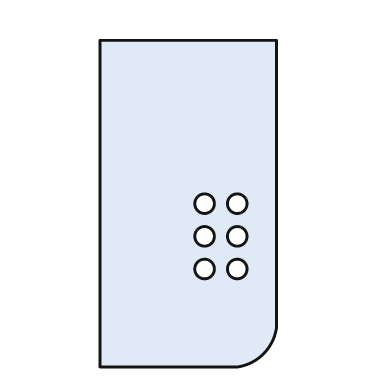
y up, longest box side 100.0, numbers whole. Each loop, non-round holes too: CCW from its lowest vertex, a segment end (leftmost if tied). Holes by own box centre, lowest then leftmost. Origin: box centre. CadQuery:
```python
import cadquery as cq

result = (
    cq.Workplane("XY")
    .moveTo(-27.0, -50.0)
    .lineTo(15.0, -50.0)
    .threePointArc((23.0, -46.0), (27.0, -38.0))
    .lineTo(27.0, 50.0)
    .lineTo(-27.0, 50.0)
    .close()
    .moveTo(5.0, -20.0)
    .circle(3.0)
    .moveTo(15.0, -20.0)
    .circle(3.0)
    .moveTo(5.0, -10.0)
    .circle(3.0)
    .moveTo(15.0, -10.0)
    .circle(3.0)
    .moveTo(5.0, 0.0)
    .circle(3.0)
    .moveTo(15.0, 0.0)
    .circle(3.0)
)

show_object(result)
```